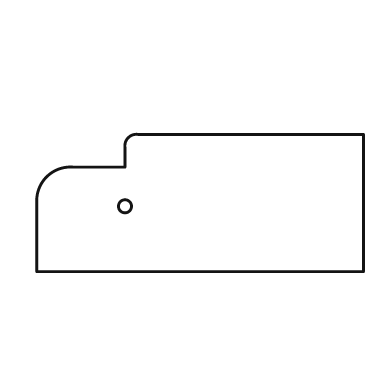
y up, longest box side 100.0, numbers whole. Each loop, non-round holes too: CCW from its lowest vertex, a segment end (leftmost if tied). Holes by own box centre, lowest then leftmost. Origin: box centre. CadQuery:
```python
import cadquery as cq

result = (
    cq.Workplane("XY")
    .moveTo(-50.0, -21.0)
    .lineTo(50.0, -21.0)
    .lineTo(50.0, 21.0)
    .lineTo(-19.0, 21.0)
    .threePointArc((-22.0, 20.0), (-23.0, 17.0))
    .lineTo(-23.0, 11.0)
    .lineTo(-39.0, 11.0)
    .threePointArc((-47.0, 8.0), (-50.0, 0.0))
    .close()
    .moveTo(-23.0, -1.0)
    .circle(2.0)
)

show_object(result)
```